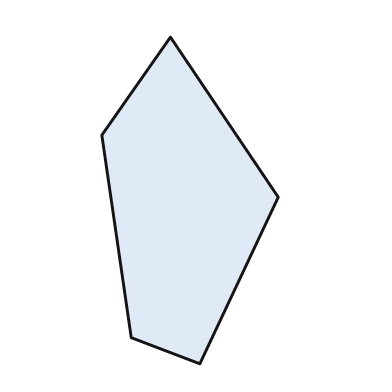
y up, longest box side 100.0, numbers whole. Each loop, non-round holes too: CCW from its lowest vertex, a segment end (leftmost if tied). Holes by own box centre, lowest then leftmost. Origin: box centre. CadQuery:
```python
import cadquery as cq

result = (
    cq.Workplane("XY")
    .moveTo(3.0, -50.0)
    .lineTo(27.0, 1.0)
    .lineTo(-6.0, 50.0)
    .lineTo(-27.0, 20.0)
    .lineTo(-18.0, -42.0)
    .close()
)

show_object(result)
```